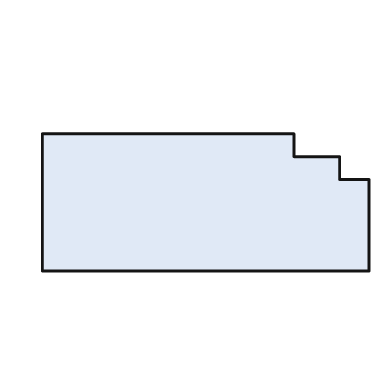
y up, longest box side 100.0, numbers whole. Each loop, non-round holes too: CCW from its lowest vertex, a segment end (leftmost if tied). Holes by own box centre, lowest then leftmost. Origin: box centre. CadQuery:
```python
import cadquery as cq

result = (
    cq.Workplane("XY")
    .moveTo(-50.0, -21.0)
    .lineTo(50.0, -21.0)
    .lineTo(50.0, 7.0)
    .lineTo(41.0, 7.0)
    .lineTo(41.0, 14.0)
    .lineTo(27.0, 14.0)
    .lineTo(27.0, 21.0)
    .lineTo(-50.0, 21.0)
    .close()
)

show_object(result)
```